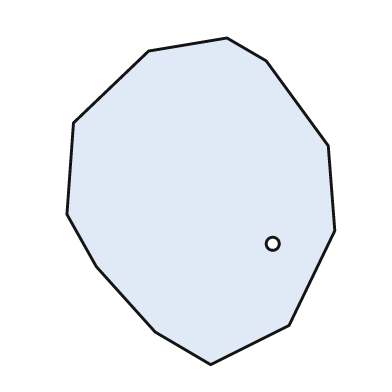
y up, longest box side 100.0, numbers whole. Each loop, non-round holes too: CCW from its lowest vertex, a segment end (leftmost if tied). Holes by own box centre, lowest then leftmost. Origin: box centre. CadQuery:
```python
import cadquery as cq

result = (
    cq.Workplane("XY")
    .moveTo(3.0, -50.0)
    .lineTo(27.0, -38.0)
    .lineTo(41.0, -9.0)
    .lineTo(39.0, 17.0)
    .lineTo(20.0, 43.0)
    .lineTo(8.0, 50.0)
    .lineTo(-16.0, 46.0)
    .lineTo(-39.0, 24.0)
    .lineTo(-41.0, -4.0)
    .lineTo(-32.0, -20.0)
    .lineTo(-14.0, -40.0)
    .close()
    .moveTo(22.0, -13.0)
    .circle(2.0)
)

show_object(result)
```